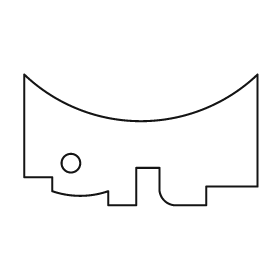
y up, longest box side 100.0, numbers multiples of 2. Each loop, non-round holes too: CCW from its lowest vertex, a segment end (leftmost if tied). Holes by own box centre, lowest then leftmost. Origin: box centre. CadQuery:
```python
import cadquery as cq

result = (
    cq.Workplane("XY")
    .moveTo(-14.0, -28.0)
    .lineTo(-2.0, -28.0)
    .lineTo(-2.0, -12.0)
    .lineTo(8.0, -12.0)
    .lineTo(8.0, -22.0)
    .threePointArc((10.0, -26.0), (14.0, -28.0))
    .lineTo(28.0, -28.0)
    .lineTo(28.0, -20.0)
    .lineTo(50.0, -20.0)
    .lineTo(50.0, 28.0)
    .threePointArc((0.0, 8.0), (-50.0, 28.0))
    .lineTo(-50.0, -16.0)
    .lineTo(-38.0, -16.0)
    .lineTo(-38.0, -22.0)
    .threePointArc((-26.0, -24.0), (-14.0, -22.0))
    .close()
    .moveTo(-30.0, -10.0)
    .circle(4.0)
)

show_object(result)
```